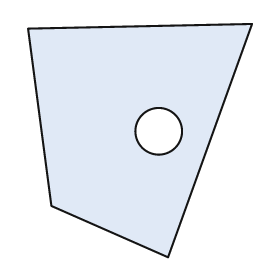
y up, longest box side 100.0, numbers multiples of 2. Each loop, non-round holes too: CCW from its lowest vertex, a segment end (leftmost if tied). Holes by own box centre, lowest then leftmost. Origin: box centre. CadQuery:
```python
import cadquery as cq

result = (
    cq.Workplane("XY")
    .moveTo(12.0, -50.0)
    .lineTo(48.0, 50.0)
    .lineTo(-48.0, 48.0)
    .lineTo(-38.0, -28.0)
    .close()
    .moveTo(8.0, 4.0)
    .circle(10.0)
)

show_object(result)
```